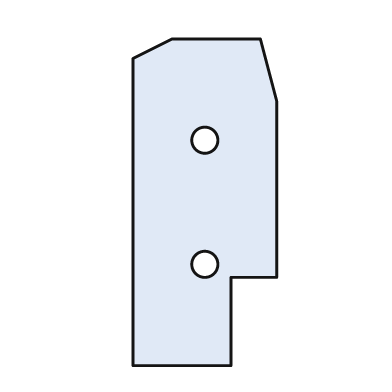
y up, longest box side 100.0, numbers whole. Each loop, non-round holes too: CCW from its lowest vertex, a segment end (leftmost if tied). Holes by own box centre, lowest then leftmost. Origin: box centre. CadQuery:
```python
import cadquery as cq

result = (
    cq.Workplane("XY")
    .moveTo(-22.0, -50.0)
    .lineTo(8.0, -50.0)
    .lineTo(8.0, -23.0)
    .lineTo(22.0, -23.0)
    .lineTo(22.0, 31.0)
    .lineTo(17.0, 50.0)
    .lineTo(-10.0, 50.0)
    .lineTo(-22.0, 44.0)
    .close()
    .moveTo(0.0, -19.0)
    .circle(4.0)
    .moveTo(0.0, 19.0)
    .circle(4.0)
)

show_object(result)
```